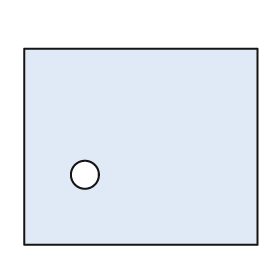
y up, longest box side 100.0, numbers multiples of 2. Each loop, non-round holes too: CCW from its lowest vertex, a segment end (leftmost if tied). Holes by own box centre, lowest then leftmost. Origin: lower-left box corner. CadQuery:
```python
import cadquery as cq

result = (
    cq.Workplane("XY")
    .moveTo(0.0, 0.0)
    .lineTo(100.0, 0.0)
    .lineTo(100.0, 84.0)
    .lineTo(0.0, 84.0)
    .close()
    .moveTo(26.0, 30.0)
    .circle(6.0)
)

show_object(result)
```